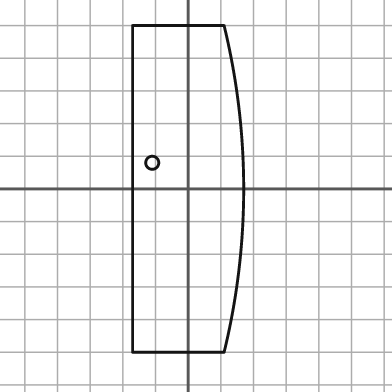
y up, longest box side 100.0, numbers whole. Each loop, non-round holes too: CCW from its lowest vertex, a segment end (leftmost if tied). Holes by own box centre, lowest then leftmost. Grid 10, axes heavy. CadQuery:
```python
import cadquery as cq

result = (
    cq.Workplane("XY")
    .moveTo(-17.0, -50.0)
    .lineTo(11.0, -50.0)
    .threePointArc((17.0, 0.0), (11.0, 50.0))
    .lineTo(-17.0, 50.0)
    .close()
    .moveTo(-11.0, 8.0)
    .circle(2.0)
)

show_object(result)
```